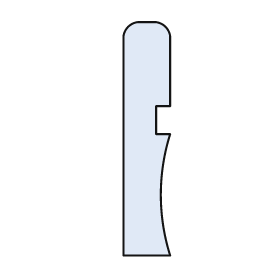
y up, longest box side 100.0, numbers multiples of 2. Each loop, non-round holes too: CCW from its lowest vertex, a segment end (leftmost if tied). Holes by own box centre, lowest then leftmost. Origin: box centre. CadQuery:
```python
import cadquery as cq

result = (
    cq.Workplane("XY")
    .moveTo(-10.0, -50.0)
    .lineTo(10.0, -50.0)
    .threePointArc((6.0, -24.0), (10.0, 2.0))
    .lineTo(4.0, 2.0)
    .lineTo(4.0, 14.0)
    .lineTo(10.0, 14.0)
    .lineTo(10.0, 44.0)
    .threePointArc((8.0, 48.0), (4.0, 50.0))
    .lineTo(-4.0, 50.0)
    .threePointArc((-8.0, 48.0), (-10.0, 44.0))
    .close()
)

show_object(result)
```